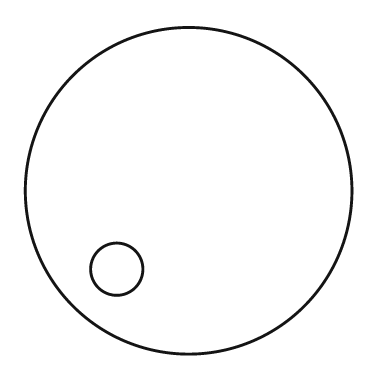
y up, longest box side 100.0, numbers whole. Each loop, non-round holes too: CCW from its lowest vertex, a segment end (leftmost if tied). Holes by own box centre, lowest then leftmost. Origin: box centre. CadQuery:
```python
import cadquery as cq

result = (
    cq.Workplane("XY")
    .moveTo(0.0, 0.0)
    .circle(50.0)
    .moveTo(-22.0, -24.0)
    .circle(8.0)
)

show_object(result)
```